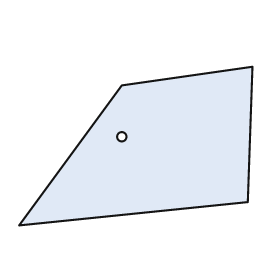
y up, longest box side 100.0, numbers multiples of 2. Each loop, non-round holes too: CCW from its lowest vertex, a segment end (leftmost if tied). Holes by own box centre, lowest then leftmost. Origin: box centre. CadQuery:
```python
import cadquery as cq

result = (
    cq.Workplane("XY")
    .moveTo(-50.0, -34.0)
    .lineTo(48.0, -24.0)
    .lineTo(50.0, 34.0)
    .lineTo(-6.0, 26.0)
    .close()
    .moveTo(-6.0, 4.0)
    .circle(2.0)
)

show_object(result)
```